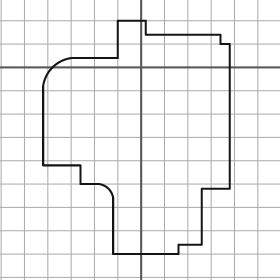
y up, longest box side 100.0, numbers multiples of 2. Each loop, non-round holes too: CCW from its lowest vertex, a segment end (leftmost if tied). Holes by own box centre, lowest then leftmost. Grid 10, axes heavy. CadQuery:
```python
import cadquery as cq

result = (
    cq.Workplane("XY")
    .moveTo(-12.0, -80.0)
    .lineTo(16.0, -80.0)
    .lineTo(16.0, -76.0)
    .lineTo(26.0, -76.0)
    .lineTo(26.0, -52.0)
    .lineTo(38.0, -52.0)
    .lineTo(38.0, 10.0)
    .lineTo(34.0, 10.0)
    .lineTo(34.0, 14.0)
    .lineTo(2.0, 14.0)
    .lineTo(2.0, 20.0)
    .lineTo(-10.0, 20.0)
    .lineTo(-10.0, 4.0)
    .lineTo(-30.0, 4.0)
    .threePointArc((-38.0, 0.0), (-42.0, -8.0))
    .lineTo(-42.0, -42.0)
    .lineTo(-26.0, -42.0)
    .lineTo(-26.0, -50.0)
    .lineTo(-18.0, -50.0)
    .threePointArc((-14.0, -52.0), (-12.0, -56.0))
    .close()
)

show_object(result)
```